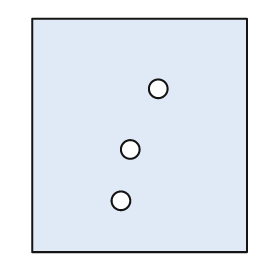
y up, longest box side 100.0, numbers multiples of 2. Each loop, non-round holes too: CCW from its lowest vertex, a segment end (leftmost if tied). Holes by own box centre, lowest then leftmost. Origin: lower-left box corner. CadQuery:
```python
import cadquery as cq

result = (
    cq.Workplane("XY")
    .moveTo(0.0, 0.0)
    .lineTo(92.0, 0.0)
    .lineTo(92.0, 100.0)
    .lineTo(0.0, 100.0)
    .close()
    .moveTo(38.0, 22.0)
    .circle(4.0)
    .moveTo(42.0, 44.0)
    .circle(4.0)
    .moveTo(54.0, 70.0)
    .circle(4.0)
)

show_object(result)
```